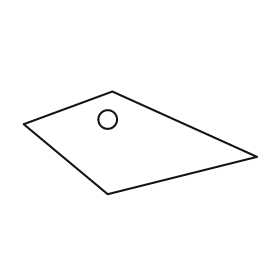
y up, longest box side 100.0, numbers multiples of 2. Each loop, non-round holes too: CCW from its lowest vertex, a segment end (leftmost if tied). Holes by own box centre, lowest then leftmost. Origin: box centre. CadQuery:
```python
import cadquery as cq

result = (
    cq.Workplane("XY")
    .moveTo(-14.0, -22.0)
    .lineTo(50.0, -6.0)
    .lineTo(-12.0, 22.0)
    .lineTo(-50.0, 8.0)
    .close()
    .moveTo(-14.0, 10.0)
    .circle(4.0)
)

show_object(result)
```